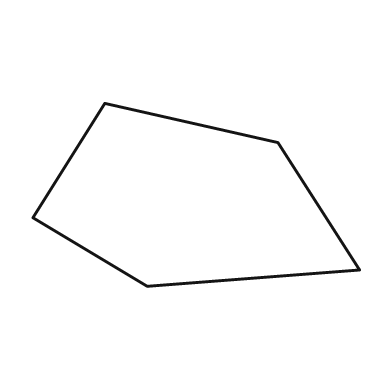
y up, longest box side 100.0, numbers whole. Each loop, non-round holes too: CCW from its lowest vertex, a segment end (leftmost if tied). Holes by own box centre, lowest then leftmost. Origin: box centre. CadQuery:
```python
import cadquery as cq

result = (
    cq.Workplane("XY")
    .moveTo(-15.0, -28.0)
    .lineTo(50.0, -23.0)
    .lineTo(25.0, 16.0)
    .lineTo(-28.0, 28.0)
    .lineTo(-50.0, -7.0)
    .close()
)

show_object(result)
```